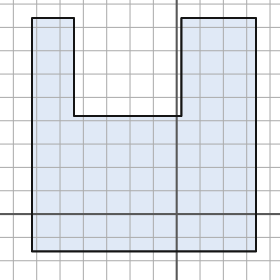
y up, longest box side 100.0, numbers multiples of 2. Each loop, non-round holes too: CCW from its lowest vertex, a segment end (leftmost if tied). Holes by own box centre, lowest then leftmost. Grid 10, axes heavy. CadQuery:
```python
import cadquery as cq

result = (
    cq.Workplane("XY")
    .moveTo(-62.0, -16.0)
    .lineTo(34.0, -16.0)
    .lineTo(34.0, 84.0)
    .lineTo(2.0, 84.0)
    .lineTo(2.0, 42.0)
    .lineTo(-44.0, 42.0)
    .lineTo(-44.0, 84.0)
    .lineTo(-62.0, 84.0)
    .close()
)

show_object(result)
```